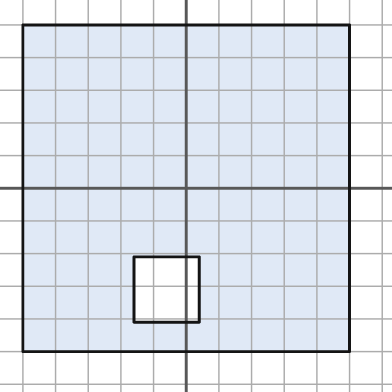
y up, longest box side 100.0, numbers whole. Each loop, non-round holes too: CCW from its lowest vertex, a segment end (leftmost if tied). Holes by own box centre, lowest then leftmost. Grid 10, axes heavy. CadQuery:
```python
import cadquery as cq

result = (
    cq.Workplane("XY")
    .moveTo(-50.0, -50.0)
    .lineTo(50.0, -50.0)
    .lineTo(50.0, 50.0)
    .lineTo(-50.0, 50.0)
    .close()
    .moveTo(-16.0, -41.0)
    .lineTo(4.0, -41.0)
    .lineTo(4.0, -21.0)
    .lineTo(-16.0, -21.0)
    .close()
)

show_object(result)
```